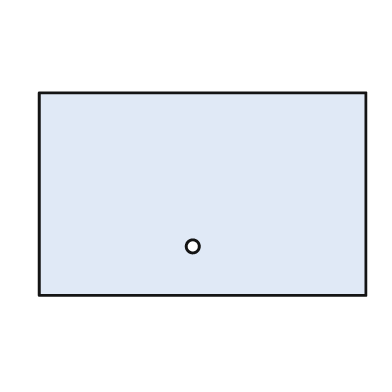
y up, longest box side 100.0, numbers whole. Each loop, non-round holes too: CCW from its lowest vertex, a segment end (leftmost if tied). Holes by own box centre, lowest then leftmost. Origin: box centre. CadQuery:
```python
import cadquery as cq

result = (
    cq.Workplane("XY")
    .moveTo(-50.0, -31.0)
    .lineTo(50.0, -31.0)
    .lineTo(50.0, 31.0)
    .lineTo(-50.0, 31.0)
    .close()
    .moveTo(-3.0, -16.0)
    .circle(2.0)
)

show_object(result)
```